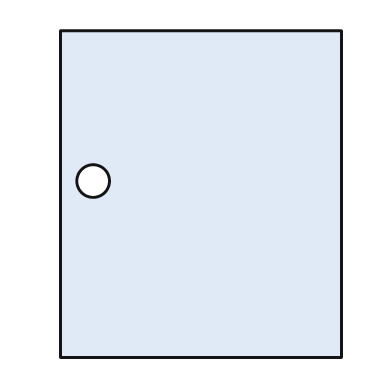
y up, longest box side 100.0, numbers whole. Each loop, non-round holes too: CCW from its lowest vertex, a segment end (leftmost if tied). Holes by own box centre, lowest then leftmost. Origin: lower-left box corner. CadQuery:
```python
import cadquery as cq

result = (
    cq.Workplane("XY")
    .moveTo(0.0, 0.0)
    .lineTo(86.0, 0.0)
    .lineTo(86.0, 100.0)
    .lineTo(0.0, 100.0)
    .close()
    .moveTo(10.0, 54.0)
    .circle(5.0)
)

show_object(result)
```